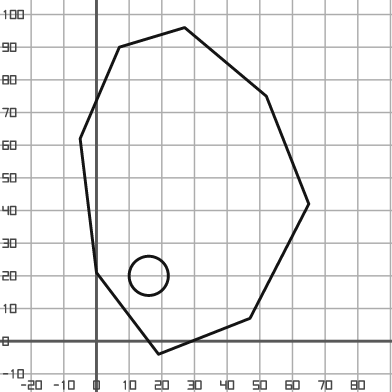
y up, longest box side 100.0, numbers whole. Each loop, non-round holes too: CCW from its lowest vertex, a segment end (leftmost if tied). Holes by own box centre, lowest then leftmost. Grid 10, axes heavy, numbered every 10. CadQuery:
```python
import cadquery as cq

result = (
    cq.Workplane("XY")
    .moveTo(19.0, -4.0)
    .lineTo(47.0, 7.0)
    .lineTo(65.0, 42.0)
    .lineTo(52.0, 75.0)
    .lineTo(27.0, 96.0)
    .lineTo(7.0, 90.0)
    .lineTo(-5.0, 62.0)
    .lineTo(0.0, 21.0)
    .close()
    .moveTo(16.0, 20.0)
    .circle(6.0)
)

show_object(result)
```